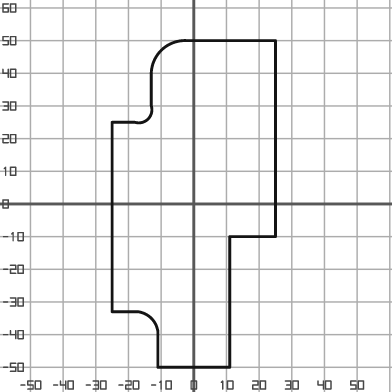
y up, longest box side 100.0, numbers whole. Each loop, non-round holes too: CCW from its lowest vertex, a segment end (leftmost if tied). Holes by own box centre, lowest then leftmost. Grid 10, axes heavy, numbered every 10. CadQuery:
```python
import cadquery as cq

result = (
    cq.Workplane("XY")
    .moveTo(-11.0, -50.0)
    .lineTo(11.0, -50.0)
    .lineTo(11.0, -10.0)
    .lineTo(25.0, -10.0)
    .lineTo(25.0, 50.0)
    .lineTo(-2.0, 50.0)
    .threePointArc((-10.0, 47.0), (-13.0, 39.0))
    .lineTo(-13.0, 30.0)
    .threePointArc((-14.0, 26.0), (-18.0, 25.0))
    .lineTo(-25.0, 25.0)
    .lineTo(-25.0, -33.0)
    .lineTo(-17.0, -33.0)
    .threePointArc((-13.0, -35.0), (-11.0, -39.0))
    .close()
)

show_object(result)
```